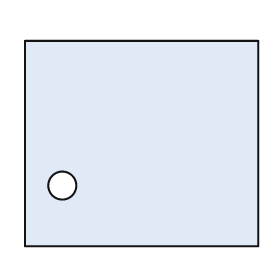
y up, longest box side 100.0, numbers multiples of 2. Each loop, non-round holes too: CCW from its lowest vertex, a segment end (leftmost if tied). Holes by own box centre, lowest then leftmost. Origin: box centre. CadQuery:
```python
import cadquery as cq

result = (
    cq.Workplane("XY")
    .moveTo(-50.0, -44.0)
    .lineTo(50.0, -44.0)
    .lineTo(50.0, 44.0)
    .lineTo(-50.0, 44.0)
    .close()
    .moveTo(-34.0, -18.0)
    .circle(6.0)
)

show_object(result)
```